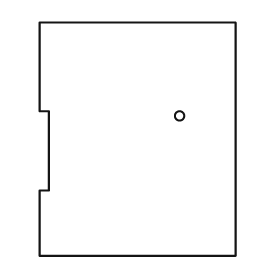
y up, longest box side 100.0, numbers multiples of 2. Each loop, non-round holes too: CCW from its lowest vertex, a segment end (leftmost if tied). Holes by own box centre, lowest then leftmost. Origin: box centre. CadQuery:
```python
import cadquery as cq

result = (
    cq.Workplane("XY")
    .moveTo(-42.0, -50.0)
    .lineTo(42.0, -50.0)
    .lineTo(42.0, 50.0)
    .lineTo(-42.0, 50.0)
    .lineTo(-42.0, 12.0)
    .lineTo(-38.0, 12.0)
    .lineTo(-38.0, -22.0)
    .lineTo(-42.0, -22.0)
    .close()
    .moveTo(18.0, 10.0)
    .circle(2.0)
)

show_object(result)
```